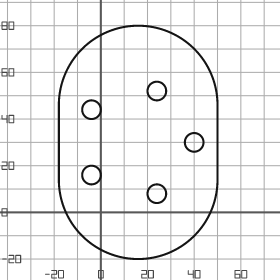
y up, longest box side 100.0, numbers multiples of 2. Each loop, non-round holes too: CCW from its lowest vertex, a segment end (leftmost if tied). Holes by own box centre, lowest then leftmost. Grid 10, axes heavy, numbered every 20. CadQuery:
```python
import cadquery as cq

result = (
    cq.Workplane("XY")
    .moveTo(-18.0, 14.0)
    .threePointArc((16.0, -20.0), (50.0, 14.0))
    .lineTo(50.0, 46.0)
    .threePointArc((16.0, 80.0), (-18.0, 46.0))
    .close()
    .moveTo(24.0, 8.0)
    .circle(4.0)
    .moveTo(-4.0, 16.0)
    .circle(4.0)
    .moveTo(40.0, 30.0)
    .circle(4.0)
    .moveTo(-4.0, 44.0)
    .circle(4.0)
    .moveTo(24.0, 52.0)
    .circle(4.0)
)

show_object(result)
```